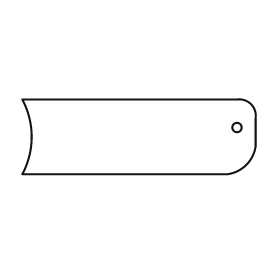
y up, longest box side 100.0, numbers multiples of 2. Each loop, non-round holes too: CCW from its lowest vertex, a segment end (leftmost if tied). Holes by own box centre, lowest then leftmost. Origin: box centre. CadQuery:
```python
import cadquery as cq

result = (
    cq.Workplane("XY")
    .moveTo(-50.0, -16.0)
    .lineTo(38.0, -16.0)
    .threePointArc((46.0, -12.0), (50.0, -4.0))
    .lineTo(50.0, 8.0)
    .threePointArc((48.0, 14.0), (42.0, 16.0))
    .lineTo(-50.0, 16.0)
    .threePointArc((-46.0, 0.0), (-50.0, -16.0))
    .close()
    .moveTo(42.0, 4.0)
    .circle(2.0)
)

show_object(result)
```